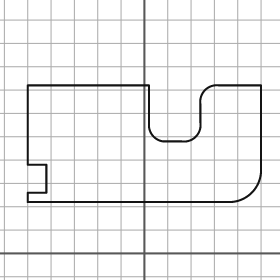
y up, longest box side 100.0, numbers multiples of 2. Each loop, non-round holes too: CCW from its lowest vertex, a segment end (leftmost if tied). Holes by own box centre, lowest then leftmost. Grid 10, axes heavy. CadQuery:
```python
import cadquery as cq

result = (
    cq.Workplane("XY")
    .moveTo(-50.0, 22.0)
    .lineTo(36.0, 22.0)
    .threePointArc((46.0, 26.0), (50.0, 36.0))
    .lineTo(50.0, 72.0)
    .lineTo(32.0, 72.0)
    .threePointArc((26.0, 70.0), (24.0, 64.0))
    .lineTo(24.0, 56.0)
    .threePointArc((22.0, 50.0), (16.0, 48.0))
    .lineTo(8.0, 48.0)
    .threePointArc((4.0, 50.0), (2.0, 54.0))
    .lineTo(2.0, 72.0)
    .lineTo(-50.0, 72.0)
    .lineTo(-50.0, 38.0)
    .lineTo(-42.0, 38.0)
    .lineTo(-42.0, 26.0)
    .lineTo(-50.0, 26.0)
    .close()
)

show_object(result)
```